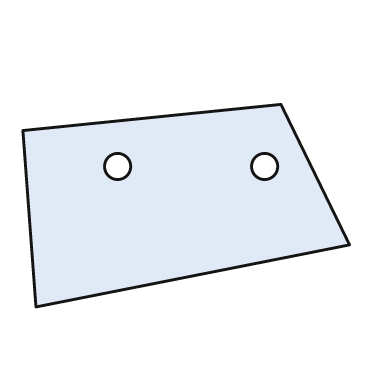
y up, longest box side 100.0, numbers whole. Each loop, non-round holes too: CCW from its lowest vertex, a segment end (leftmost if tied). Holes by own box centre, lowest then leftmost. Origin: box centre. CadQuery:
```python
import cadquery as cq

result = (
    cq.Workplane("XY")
    .moveTo(-46.0, -31.0)
    .lineTo(50.0, -12.0)
    .lineTo(29.0, 31.0)
    .lineTo(-50.0, 23.0)
    .close()
    .moveTo(-21.0, 12.0)
    .circle(4.0)
    .moveTo(24.0, 12.0)
    .circle(4.0)
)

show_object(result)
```